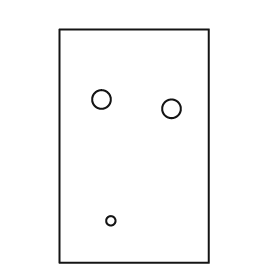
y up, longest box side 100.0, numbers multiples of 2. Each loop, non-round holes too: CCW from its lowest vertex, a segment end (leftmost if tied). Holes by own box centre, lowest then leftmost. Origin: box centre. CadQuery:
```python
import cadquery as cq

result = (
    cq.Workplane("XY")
    .moveTo(-32.0, -50.0)
    .lineTo(32.0, -50.0)
    .lineTo(32.0, 50.0)
    .lineTo(-32.0, 50.0)
    .close()
    .moveTo(-10.0, -32.0)
    .circle(2.0)
    .moveTo(16.0, 16.0)
    .circle(4.0)
    .moveTo(-14.0, 20.0)
    .circle(4.0)
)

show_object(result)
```